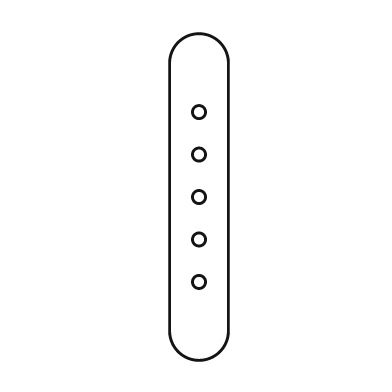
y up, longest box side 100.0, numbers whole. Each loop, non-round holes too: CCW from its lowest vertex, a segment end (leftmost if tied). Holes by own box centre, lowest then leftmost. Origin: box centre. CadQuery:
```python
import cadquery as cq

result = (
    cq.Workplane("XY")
    .moveTo(-9.0, -41.0)
    .threePointArc((0.0, -50.0), (9.0, -41.0))
    .lineTo(9.0, 41.0)
    .threePointArc((0.0, 50.0), (-9.0, 41.0))
    .close()
    .moveTo(0.0, -26.0)
    .circle(2.0)
    .moveTo(0.0, -13.0)
    .circle(2.0)
    .moveTo(0.0, 0.0)
    .circle(2.0)
    .moveTo(0.0, 13.0)
    .circle(2.0)
    .moveTo(0.0, 26.0)
    .circle(2.0)
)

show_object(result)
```